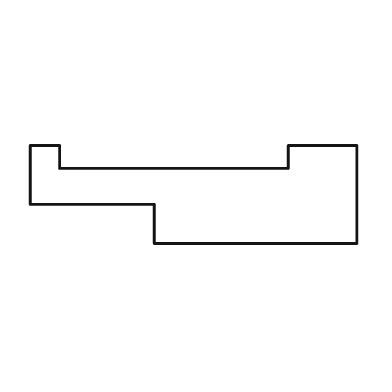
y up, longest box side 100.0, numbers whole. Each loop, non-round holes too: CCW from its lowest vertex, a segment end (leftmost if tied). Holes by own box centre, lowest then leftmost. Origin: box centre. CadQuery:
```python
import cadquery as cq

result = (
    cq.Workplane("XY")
    .moveTo(-12.0, -15.0)
    .lineTo(50.0, -15.0)
    .lineTo(50.0, 15.0)
    .lineTo(29.0, 15.0)
    .lineTo(29.0, 8.0)
    .lineTo(-41.0, 8.0)
    .lineTo(-41.0, 15.0)
    .lineTo(-50.0, 15.0)
    .lineTo(-50.0, -3.0)
    .lineTo(-12.0, -3.0)
    .close()
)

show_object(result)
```